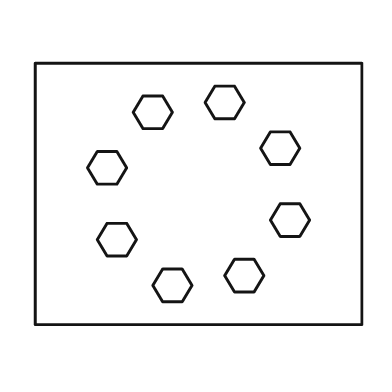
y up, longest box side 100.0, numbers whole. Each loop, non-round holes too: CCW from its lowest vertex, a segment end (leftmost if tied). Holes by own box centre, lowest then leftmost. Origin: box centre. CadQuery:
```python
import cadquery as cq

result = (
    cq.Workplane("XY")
    .moveTo(-50.0, -40.0)
    .lineTo(50.0, -40.0)
    .lineTo(50.0, 40.0)
    .lineTo(-50.0, 40.0)
    .close()
    .moveTo(-11.0, -33.0)
    .lineTo(-5.0, -33.0)
    .lineTo(-2.0, -28.0)
    .lineTo(-5.0, -23.0)
    .lineTo(-11.0, -23.0)
    .lineTo(-14.0, -28.0)
    .close()
    .moveTo(11.0, -30.0)
    .lineTo(17.0, -30.0)
    .lineTo(20.0, -25.0)
    .lineTo(17.0, -20.0)
    .lineTo(11.0, -20.0)
    .lineTo(8.0, -25.0)
    .close()
    .moveTo(-28.0, -19.0)
    .lineTo(-22.0, -19.0)
    .lineTo(-19.0, -14.0)
    .lineTo(-22.0, -9.0)
    .lineTo(-28.0, -9.0)
    .lineTo(-31.0, -14.0)
    .close()
    .moveTo(25.0, -13.0)
    .lineTo(31.0, -13.0)
    .lineTo(34.0, -8.0)
    .lineTo(31.0, -3.0)
    .lineTo(25.0, -3.0)
    .lineTo(22.0, -8.0)
    .close()
    .moveTo(-31.0, 3.0)
    .lineTo(-25.0, 3.0)
    .lineTo(-22.0, 8.0)
    .lineTo(-25.0, 13.0)
    .lineTo(-31.0, 13.0)
    .lineTo(-34.0, 8.0)
    .close()
    .moveTo(22.0, 9.0)
    .lineTo(28.0, 9.0)
    .lineTo(31.0, 14.0)
    .lineTo(28.0, 19.0)
    .lineTo(22.0, 19.0)
    .lineTo(19.0, 14.0)
    .close()
    .moveTo(-17.0, 20.0)
    .lineTo(-11.0, 20.0)
    .lineTo(-8.0, 25.0)
    .lineTo(-11.0, 30.0)
    .lineTo(-17.0, 30.0)
    .lineTo(-20.0, 25.0)
    .close()
    .moveTo(5.0, 23.0)
    .lineTo(11.0, 23.0)
    .lineTo(14.0, 28.0)
    .lineTo(11.0, 33.0)
    .lineTo(5.0, 33.0)
    .lineTo(2.0, 28.0)
    .close()
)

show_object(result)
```